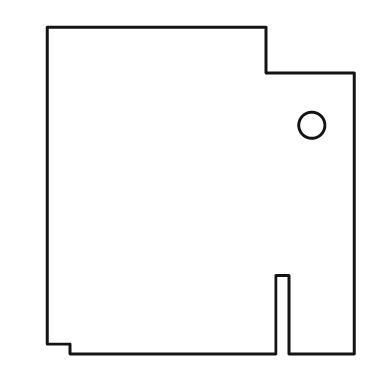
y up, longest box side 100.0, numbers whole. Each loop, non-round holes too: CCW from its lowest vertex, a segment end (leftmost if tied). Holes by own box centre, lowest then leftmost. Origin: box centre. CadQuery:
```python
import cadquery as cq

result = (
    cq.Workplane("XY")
    .moveTo(-40.0, -50.0)
    .lineTo(23.0, -50.0)
    .lineTo(23.0, -26.0)
    .lineTo(27.0, -26.0)
    .lineTo(27.0, -50.0)
    .lineTo(47.0, -50.0)
    .lineTo(47.0, 36.0)
    .lineTo(20.0, 36.0)
    .lineTo(20.0, 50.0)
    .lineTo(-47.0, 50.0)
    .lineTo(-47.0, -47.0)
    .lineTo(-40.0, -47.0)
    .close()
    .moveTo(34.0, 20.0)
    .circle(4.0)
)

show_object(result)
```